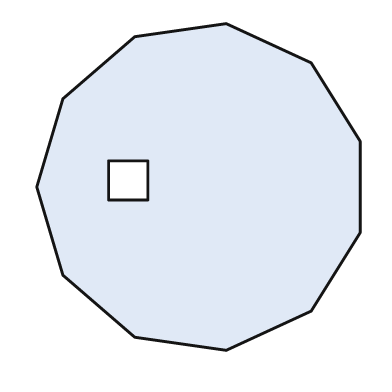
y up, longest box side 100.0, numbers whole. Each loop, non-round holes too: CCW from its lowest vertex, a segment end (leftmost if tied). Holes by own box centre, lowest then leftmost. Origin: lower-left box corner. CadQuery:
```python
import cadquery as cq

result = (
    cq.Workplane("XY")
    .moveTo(58.0, 0.0)
    .lineTo(84.0, 12.0)
    .lineTo(99.0, 36.0)
    .lineTo(99.0, 64.0)
    .lineTo(84.0, 88.0)
    .lineTo(58.0, 100.0)
    .lineTo(30.0, 96.0)
    .lineTo(8.0, 77.0)
    .lineTo(0.0, 50.0)
    .lineTo(8.0, 23.0)
    .lineTo(30.0, 4.0)
    .close()
    .moveTo(22.0, 46.0)
    .lineTo(34.0, 46.0)
    .lineTo(34.0, 58.0)
    .lineTo(22.0, 58.0)
    .close()
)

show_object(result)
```